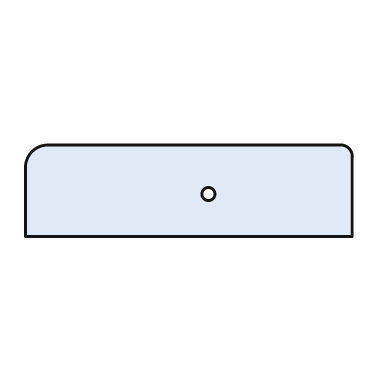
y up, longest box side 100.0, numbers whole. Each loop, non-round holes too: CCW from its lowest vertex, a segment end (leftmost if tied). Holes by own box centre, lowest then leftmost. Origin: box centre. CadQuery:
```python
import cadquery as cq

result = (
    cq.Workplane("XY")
    .moveTo(-50.0, -14.0)
    .lineTo(50.0, -14.0)
    .lineTo(50.0, 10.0)
    .threePointArc((49.0, 13.0), (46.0, 14.0))
    .lineTo(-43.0, 14.0)
    .threePointArc((-48.0, 12.0), (-50.0, 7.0))
    .close()
    .moveTo(6.0, -1.0)
    .circle(2.0)
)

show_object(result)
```